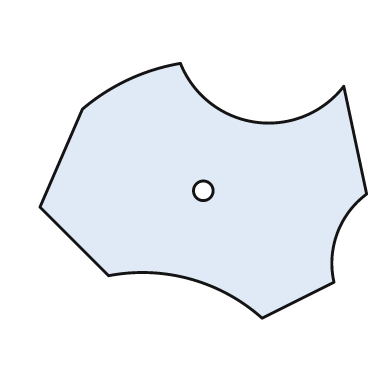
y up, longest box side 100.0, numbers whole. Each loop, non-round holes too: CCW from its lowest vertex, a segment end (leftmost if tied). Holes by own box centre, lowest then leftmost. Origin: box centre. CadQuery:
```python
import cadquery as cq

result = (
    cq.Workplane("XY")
    .moveTo(18.0, -39.0)
    .lineTo(40.0, -28.0)
    .threePointArc((41.0, -13.0), (50.0, -1.0))
    .lineTo(43.0, 32.0)
    .threePointArc((16.0, 21.0), (-7.0, 39.0))
    .threePointArc((-23.0, 34.0), (-37.0, 25.0))
    .lineTo(-50.0, -5.0)
    .lineTo(-29.0, -26.0)
    .threePointArc((-4.0, -27.0), (18.0, -39.0))
    .close()
    .moveTo(0.0, 0.0)
    .circle(3.0)
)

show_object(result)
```